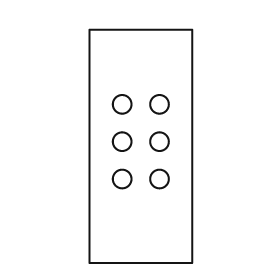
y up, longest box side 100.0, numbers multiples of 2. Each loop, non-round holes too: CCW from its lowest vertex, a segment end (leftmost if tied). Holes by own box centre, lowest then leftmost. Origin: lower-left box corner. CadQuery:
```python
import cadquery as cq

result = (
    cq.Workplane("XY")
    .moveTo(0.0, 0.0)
    .lineTo(44.0, 0.0)
    .lineTo(44.0, 100.0)
    .lineTo(0.0, 100.0)
    .close()
    .moveTo(14.0, 36.0)
    .circle(4.0)
    .moveTo(30.0, 36.0)
    .circle(4.0)
    .moveTo(14.0, 52.0)
    .circle(4.0)
    .moveTo(30.0, 52.0)
    .circle(4.0)
    .moveTo(14.0, 68.0)
    .circle(4.0)
    .moveTo(30.0, 68.0)
    .circle(4.0)
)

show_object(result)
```